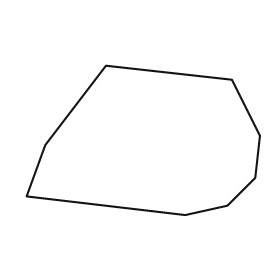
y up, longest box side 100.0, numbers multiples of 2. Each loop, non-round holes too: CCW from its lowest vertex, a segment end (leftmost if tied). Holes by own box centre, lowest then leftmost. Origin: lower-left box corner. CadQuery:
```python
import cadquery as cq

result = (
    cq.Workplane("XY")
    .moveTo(68.0, 0.0)
    .lineTo(86.0, 4.0)
    .lineTo(98.0, 16.0)
    .lineTo(100.0, 34.0)
    .lineTo(88.0, 58.0)
    .lineTo(34.0, 64.0)
    .lineTo(8.0, 30.0)
    .lineTo(0.0, 8.0)
    .close()
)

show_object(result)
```